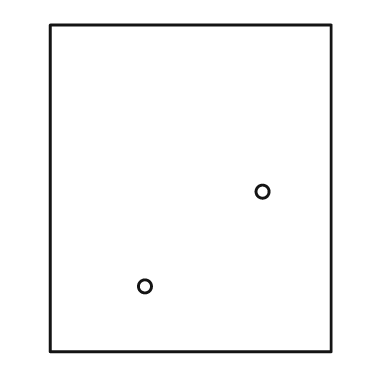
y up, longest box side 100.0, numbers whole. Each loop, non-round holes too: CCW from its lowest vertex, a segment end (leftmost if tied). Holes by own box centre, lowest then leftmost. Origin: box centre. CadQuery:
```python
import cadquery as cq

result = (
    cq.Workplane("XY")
    .moveTo(-43.0, -50.0)
    .lineTo(43.0, -50.0)
    .lineTo(43.0, 50.0)
    .lineTo(-43.0, 50.0)
    .close()
    .moveTo(-14.0, -30.0)
    .circle(2.0)
    .moveTo(22.0, -1.0)
    .circle(2.0)
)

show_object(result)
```